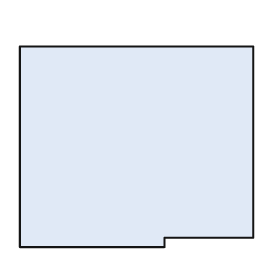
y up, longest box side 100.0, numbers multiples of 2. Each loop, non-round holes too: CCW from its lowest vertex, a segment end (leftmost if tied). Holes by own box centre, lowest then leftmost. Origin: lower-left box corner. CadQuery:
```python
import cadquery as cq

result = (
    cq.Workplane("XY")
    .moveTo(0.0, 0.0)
    .lineTo(62.0, 0.0)
    .lineTo(62.0, 4.0)
    .lineTo(100.0, 4.0)
    .lineTo(100.0, 86.0)
    .lineTo(0.0, 86.0)
    .close()
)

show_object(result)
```